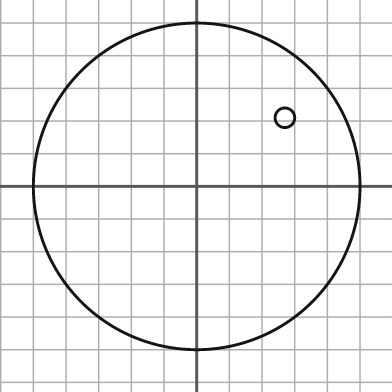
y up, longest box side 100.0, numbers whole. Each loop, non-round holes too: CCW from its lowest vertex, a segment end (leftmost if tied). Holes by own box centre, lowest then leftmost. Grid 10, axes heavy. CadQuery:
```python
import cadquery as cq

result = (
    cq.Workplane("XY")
    .moveTo(0.0, 0.0)
    .circle(50.0)
    .moveTo(27.0, 21.0)
    .circle(3.0)
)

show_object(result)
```